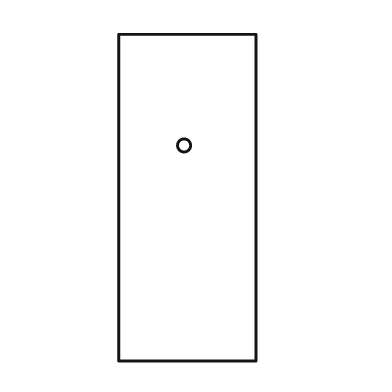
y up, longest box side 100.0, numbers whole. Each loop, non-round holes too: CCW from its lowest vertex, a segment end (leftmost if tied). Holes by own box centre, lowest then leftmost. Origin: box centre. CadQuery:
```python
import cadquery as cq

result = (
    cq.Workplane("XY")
    .moveTo(-21.0, -50.0)
    .lineTo(21.0, -50.0)
    .lineTo(21.0, 50.0)
    .lineTo(-21.0, 50.0)
    .close()
    .moveTo(-1.0, 16.0)
    .circle(2.0)
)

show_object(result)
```